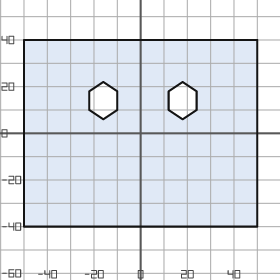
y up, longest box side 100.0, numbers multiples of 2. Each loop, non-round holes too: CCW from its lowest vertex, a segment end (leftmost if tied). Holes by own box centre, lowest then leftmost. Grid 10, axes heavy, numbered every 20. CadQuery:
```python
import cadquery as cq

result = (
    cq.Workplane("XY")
    .moveTo(-50.0, -40.0)
    .lineTo(50.0, -40.0)
    .lineTo(50.0, 40.0)
    .lineTo(-50.0, 40.0)
    .close()
    .moveTo(-16.0, 6.0)
    .lineTo(-10.0, 10.0)
    .lineTo(-10.0, 18.0)
    .lineTo(-16.0, 22.0)
    .lineTo(-22.0, 18.0)
    .lineTo(-22.0, 10.0)
    .close()
    .moveTo(18.0, 6.0)
    .lineTo(24.0, 10.0)
    .lineTo(24.0, 18.0)
    .lineTo(18.0, 22.0)
    .lineTo(12.0, 18.0)
    .lineTo(12.0, 10.0)
    .close()
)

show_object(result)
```